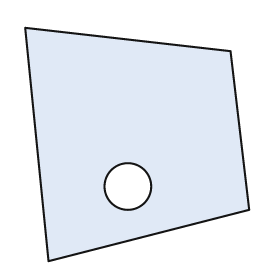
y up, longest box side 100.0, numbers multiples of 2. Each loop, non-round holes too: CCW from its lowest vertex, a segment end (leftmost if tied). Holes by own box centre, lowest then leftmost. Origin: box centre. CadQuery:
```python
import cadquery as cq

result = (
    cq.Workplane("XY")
    .moveTo(-38.0, -50.0)
    .lineTo(48.0, -28.0)
    .lineTo(40.0, 40.0)
    .lineTo(-48.0, 50.0)
    .close()
    .moveTo(-4.0, -18.0)
    .circle(10.0)
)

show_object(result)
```